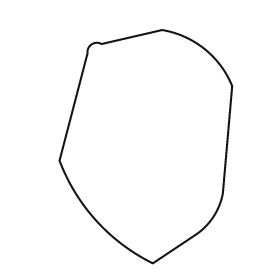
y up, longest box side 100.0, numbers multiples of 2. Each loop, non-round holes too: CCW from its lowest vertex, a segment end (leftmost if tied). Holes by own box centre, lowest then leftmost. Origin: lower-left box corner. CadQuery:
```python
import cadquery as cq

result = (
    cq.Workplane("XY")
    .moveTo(40.0, 0.0)
    .lineTo(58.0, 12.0)
    .threePointArc((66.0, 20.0), (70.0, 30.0))
    .lineTo(74.0, 76.0)
    .threePointArc((62.0, 92.0), (44.0, 100.0))
    .lineTo(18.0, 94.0)
    .threePointArc((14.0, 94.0), (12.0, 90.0))
    .lineTo(0.0, 44.0)
    .threePointArc((16.0, 18.0), (40.0, 0.0))
    .close()
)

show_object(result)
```